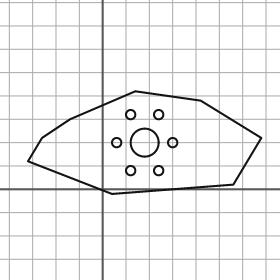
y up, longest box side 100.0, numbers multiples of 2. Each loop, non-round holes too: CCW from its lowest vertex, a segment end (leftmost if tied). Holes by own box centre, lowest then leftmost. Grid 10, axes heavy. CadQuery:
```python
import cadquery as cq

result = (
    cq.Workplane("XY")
    .moveTo(4.0, -2.0)
    .lineTo(56.0, 2.0)
    .lineTo(68.0, 22.0)
    .lineTo(42.0, 38.0)
    .lineTo(14.0, 42.0)
    .lineTo(-14.0, 30.0)
    .lineTo(-26.0, 22.0)
    .lineTo(-32.0, 12.0)
    .close()
    .moveTo(12.0, 8.0)
    .circle(2.0)
    .moveTo(24.0, 8.0)
    .circle(2.0)
    .moveTo(6.0, 20.0)
    .circle(2.0)
    .moveTo(18.0, 20.0)
    .circle(6.0)
    .moveTo(30.0, 20.0)
    .circle(2.0)
    .moveTo(12.0, 32.0)
    .circle(2.0)
    .moveTo(24.0, 32.0)
    .circle(2.0)
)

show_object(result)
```